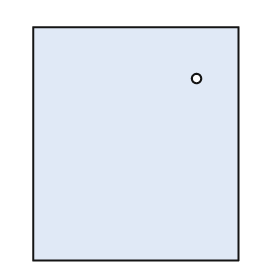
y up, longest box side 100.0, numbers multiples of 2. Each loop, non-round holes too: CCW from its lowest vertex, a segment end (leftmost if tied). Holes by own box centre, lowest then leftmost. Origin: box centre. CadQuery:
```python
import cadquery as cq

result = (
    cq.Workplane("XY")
    .moveTo(-44.0, -50.0)
    .lineTo(44.0, -50.0)
    .lineTo(44.0, 50.0)
    .lineTo(-44.0, 50.0)
    .close()
    .moveTo(26.0, 28.0)
    .circle(2.0)
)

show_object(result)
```